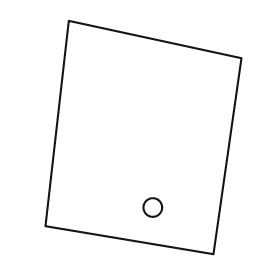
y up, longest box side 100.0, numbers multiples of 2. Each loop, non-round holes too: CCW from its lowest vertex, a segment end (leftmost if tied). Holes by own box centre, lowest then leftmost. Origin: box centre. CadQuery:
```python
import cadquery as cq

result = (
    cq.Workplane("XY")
    .moveTo(30.0, -50.0)
    .lineTo(42.0, 34.0)
    .lineTo(-32.0, 50.0)
    .lineTo(-42.0, -38.0)
    .close()
    .moveTo(4.0, -30.0)
    .circle(4.0)
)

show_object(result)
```